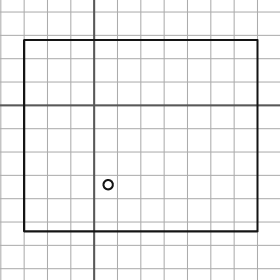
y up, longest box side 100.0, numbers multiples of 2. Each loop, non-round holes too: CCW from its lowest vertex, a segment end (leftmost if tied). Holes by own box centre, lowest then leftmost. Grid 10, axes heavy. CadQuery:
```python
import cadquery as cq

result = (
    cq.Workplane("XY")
    .moveTo(-30.0, -54.0)
    .lineTo(70.0, -54.0)
    .lineTo(70.0, 28.0)
    .lineTo(-30.0, 28.0)
    .close()
    .moveTo(6.0, -34.0)
    .circle(2.0)
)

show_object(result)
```